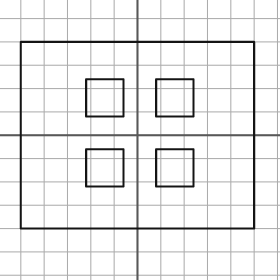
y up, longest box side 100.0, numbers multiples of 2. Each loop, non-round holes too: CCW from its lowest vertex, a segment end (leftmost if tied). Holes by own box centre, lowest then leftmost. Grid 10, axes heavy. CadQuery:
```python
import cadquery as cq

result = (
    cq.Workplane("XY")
    .moveTo(-50.0, -40.0)
    .lineTo(50.0, -40.0)
    .lineTo(50.0, 40.0)
    .lineTo(-50.0, 40.0)
    .close()
    .moveTo(-22.0, -22.0)
    .lineTo(-6.0, -22.0)
    .lineTo(-6.0, -6.0)
    .lineTo(-22.0, -6.0)
    .close()
    .moveTo(8.0, -22.0)
    .lineTo(24.0, -22.0)
    .lineTo(24.0, -6.0)
    .lineTo(8.0, -6.0)
    .close()
    .moveTo(-22.0, 8.0)
    .lineTo(-6.0, 8.0)
    .lineTo(-6.0, 24.0)
    .lineTo(-22.0, 24.0)
    .close()
    .moveTo(8.0, 8.0)
    .lineTo(24.0, 8.0)
    .lineTo(24.0, 24.0)
    .lineTo(8.0, 24.0)
    .close()
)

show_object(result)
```